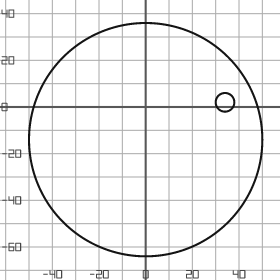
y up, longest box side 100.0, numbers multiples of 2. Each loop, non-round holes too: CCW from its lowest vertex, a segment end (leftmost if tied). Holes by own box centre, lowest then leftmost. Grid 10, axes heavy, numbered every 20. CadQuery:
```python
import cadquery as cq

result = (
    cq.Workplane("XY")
    .moveTo(0.0, -14.0)
    .circle(50.0)
    .moveTo(34.0, 2.0)
    .circle(4.0)
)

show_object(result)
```